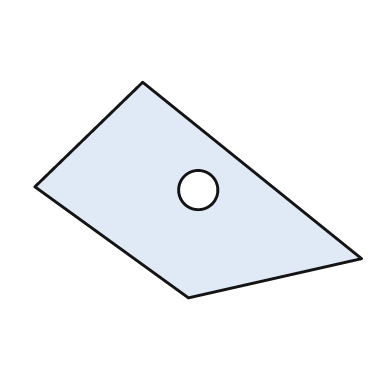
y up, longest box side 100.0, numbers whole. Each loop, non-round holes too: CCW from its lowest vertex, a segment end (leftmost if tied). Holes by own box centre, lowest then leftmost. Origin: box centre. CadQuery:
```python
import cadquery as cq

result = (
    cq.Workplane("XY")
    .moveTo(-3.0, -33.0)
    .lineTo(50.0, -21.0)
    .lineTo(-17.0, 33.0)
    .lineTo(-50.0, 1.0)
    .close()
    .moveTo(0.0, 0.0)
    .circle(6.0)
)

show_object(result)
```